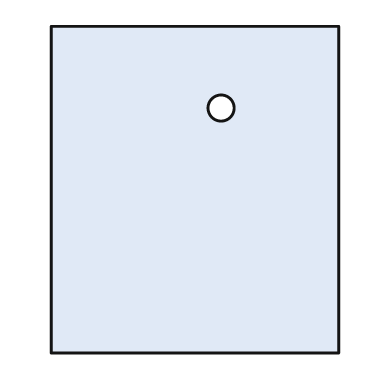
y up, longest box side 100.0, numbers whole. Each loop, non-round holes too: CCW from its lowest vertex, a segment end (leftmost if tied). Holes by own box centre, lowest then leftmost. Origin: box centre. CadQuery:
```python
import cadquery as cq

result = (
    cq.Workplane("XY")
    .moveTo(-44.0, -50.0)
    .lineTo(44.0, -50.0)
    .lineTo(44.0, 50.0)
    .lineTo(-44.0, 50.0)
    .close()
    .moveTo(8.0, 25.0)
    .circle(4.0)
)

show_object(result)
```